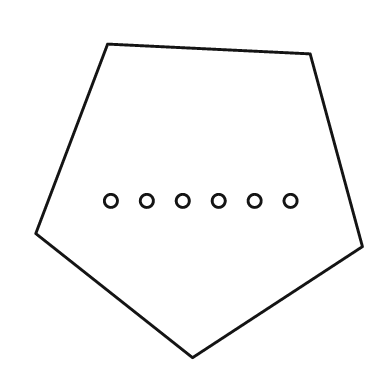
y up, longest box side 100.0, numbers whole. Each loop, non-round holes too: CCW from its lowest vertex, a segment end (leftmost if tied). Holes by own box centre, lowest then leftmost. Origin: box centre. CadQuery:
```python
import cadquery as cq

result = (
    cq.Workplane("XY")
    .moveTo(-2.0, -48.0)
    .lineTo(50.0, -14.0)
    .lineTo(34.0, 45.0)
    .lineTo(-28.0, 48.0)
    .lineTo(-50.0, -10.0)
    .close()
    .moveTo(-27.0, 0.0)
    .circle(2.0)
    .moveTo(-16.0, 0.0)
    .circle(2.0)
    .moveTo(-5.0, 0.0)
    .circle(2.0)
    .moveTo(6.0, 0.0)
    .circle(2.0)
    .moveTo(17.0, 0.0)
    .circle(2.0)
    .moveTo(28.0, 0.0)
    .circle(2.0)
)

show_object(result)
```